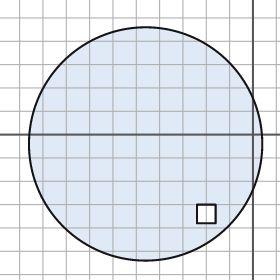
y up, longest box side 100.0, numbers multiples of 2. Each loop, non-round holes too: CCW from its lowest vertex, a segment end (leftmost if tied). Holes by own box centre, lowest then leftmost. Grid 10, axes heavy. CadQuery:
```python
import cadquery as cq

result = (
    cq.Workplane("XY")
    .moveTo(-46.0, -4.0)
    .circle(50.0)
    .moveTo(-24.0, -38.0)
    .lineTo(-16.0, -38.0)
    .lineTo(-16.0, -30.0)
    .lineTo(-24.0, -30.0)
    .close()
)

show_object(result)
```